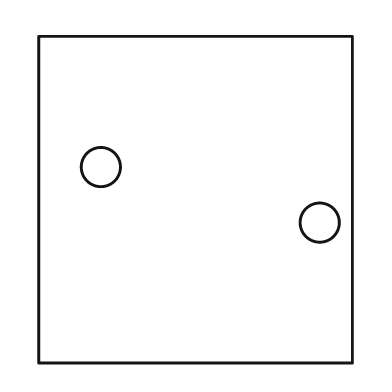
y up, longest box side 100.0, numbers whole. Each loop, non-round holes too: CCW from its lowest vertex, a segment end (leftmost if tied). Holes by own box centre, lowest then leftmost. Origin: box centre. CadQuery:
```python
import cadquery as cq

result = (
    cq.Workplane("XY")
    .moveTo(-48.0, -50.0)
    .lineTo(48.0, -50.0)
    .lineTo(48.0, 50.0)
    .lineTo(-48.0, 50.0)
    .close()
    .moveTo(38.0, -7.0)
    .circle(6.0)
    .moveTo(-29.0, 10.0)
    .circle(6.0)
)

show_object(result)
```